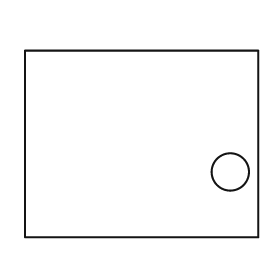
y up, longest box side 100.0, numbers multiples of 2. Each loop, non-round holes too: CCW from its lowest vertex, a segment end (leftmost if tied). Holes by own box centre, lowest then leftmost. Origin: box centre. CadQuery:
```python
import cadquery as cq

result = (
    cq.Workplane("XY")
    .moveTo(-50.0, -40.0)
    .lineTo(50.0, -40.0)
    .lineTo(50.0, 40.0)
    .lineTo(-50.0, 40.0)
    .close()
    .moveTo(38.0, -12.0)
    .circle(8.0)
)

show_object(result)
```